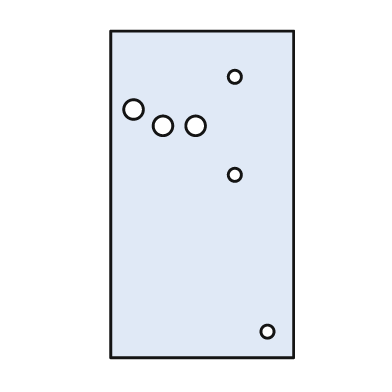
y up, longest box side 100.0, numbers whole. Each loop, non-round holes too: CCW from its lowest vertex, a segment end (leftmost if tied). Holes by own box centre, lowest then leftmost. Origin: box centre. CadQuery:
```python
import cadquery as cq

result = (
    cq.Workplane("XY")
    .moveTo(-28.0, -50.0)
    .lineTo(28.0, -50.0)
    .lineTo(28.0, 50.0)
    .lineTo(-28.0, 50.0)
    .close()
    .moveTo(20.0, -42.0)
    .circle(2.0)
    .moveTo(10.0, 6.0)
    .circle(2.0)
    .moveTo(-12.0, 21.0)
    .circle(3.0)
    .moveTo(-2.0, 21.0)
    .circle(3.0)
    .moveTo(-21.0, 26.0)
    .circle(3.0)
    .moveTo(10.0, 36.0)
    .circle(2.0)
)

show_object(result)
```